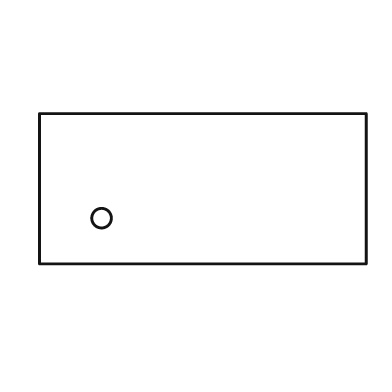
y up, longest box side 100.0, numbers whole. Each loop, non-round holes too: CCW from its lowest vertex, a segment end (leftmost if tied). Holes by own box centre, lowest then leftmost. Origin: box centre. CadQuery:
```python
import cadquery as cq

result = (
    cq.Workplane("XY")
    .moveTo(-50.0, -23.0)
    .lineTo(50.0, -23.0)
    .lineTo(50.0, 23.0)
    .lineTo(-50.0, 23.0)
    .close()
    .moveTo(-31.0, -9.0)
    .circle(3.0)
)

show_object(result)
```